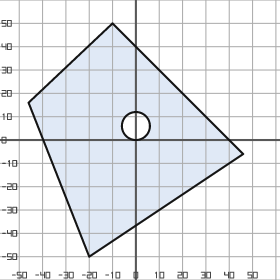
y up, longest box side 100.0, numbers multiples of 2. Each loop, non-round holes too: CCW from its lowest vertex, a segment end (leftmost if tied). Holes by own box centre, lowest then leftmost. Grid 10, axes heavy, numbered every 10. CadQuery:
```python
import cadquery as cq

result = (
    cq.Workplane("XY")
    .moveTo(-20.0, -50.0)
    .lineTo(46.0, -6.0)
    .lineTo(-10.0, 50.0)
    .lineTo(-46.0, 16.0)
    .close()
    .moveTo(0.0, 6.0)
    .circle(6.0)
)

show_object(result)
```